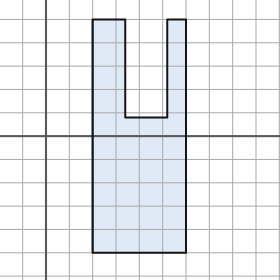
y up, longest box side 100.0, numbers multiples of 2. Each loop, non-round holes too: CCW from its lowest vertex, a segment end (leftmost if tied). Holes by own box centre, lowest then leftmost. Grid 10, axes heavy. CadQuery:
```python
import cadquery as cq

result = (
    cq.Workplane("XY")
    .moveTo(20.0, -50.0)
    .lineTo(60.0, -50.0)
    .lineTo(60.0, 50.0)
    .lineTo(52.0, 50.0)
    .lineTo(52.0, 8.0)
    .lineTo(34.0, 8.0)
    .lineTo(34.0, 50.0)
    .lineTo(20.0, 50.0)
    .close()
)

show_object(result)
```